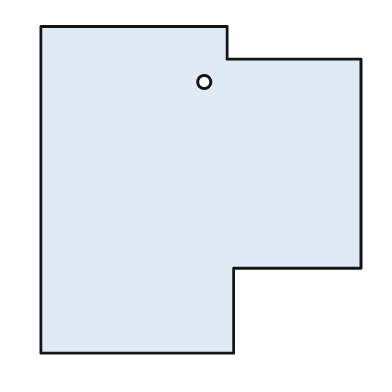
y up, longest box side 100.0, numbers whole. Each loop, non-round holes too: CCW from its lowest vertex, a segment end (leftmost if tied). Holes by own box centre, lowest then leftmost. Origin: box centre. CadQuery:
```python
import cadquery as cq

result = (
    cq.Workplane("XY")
    .moveTo(-49.0, -50.0)
    .lineTo(10.0, -50.0)
    .lineTo(10.0, -24.0)
    .lineTo(49.0, -24.0)
    .lineTo(49.0, 40.0)
    .lineTo(8.0, 40.0)
    .lineTo(8.0, 50.0)
    .lineTo(-49.0, 50.0)
    .close()
    .moveTo(1.0, 33.0)
    .circle(2.0)
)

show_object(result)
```